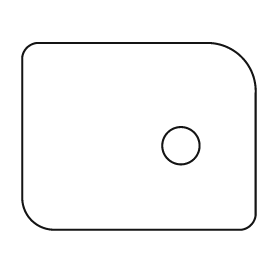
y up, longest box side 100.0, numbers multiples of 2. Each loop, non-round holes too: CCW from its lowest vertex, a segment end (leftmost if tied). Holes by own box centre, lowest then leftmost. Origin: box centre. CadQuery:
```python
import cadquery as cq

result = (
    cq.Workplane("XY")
    .moveTo(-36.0, -40.0)
    .lineTo(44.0, -40.0)
    .threePointArc((48.0, -38.0), (50.0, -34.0))
    .lineTo(50.0, 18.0)
    .threePointArc((44.0, 34.0), (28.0, 40.0))
    .lineTo(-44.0, 40.0)
    .threePointArc((-48.0, 38.0), (-50.0, 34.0))
    .lineTo(-50.0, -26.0)
    .threePointArc((-46.0, -36.0), (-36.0, -40.0))
    .close()
    .moveTo(18.0, -4.0)
    .circle(8.0)
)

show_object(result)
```